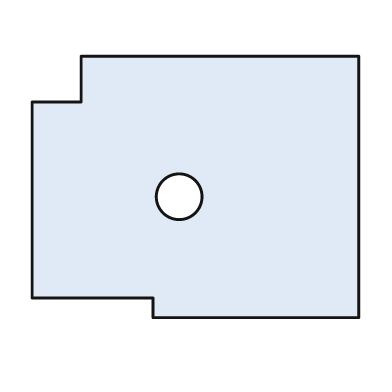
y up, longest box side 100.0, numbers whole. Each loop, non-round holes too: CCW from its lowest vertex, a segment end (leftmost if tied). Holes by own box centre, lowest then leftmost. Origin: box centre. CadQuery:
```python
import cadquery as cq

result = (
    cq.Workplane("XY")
    .moveTo(-13.0, -40.0)
    .lineTo(50.0, -40.0)
    .lineTo(50.0, 40.0)
    .lineTo(-35.0, 40.0)
    .lineTo(-35.0, 26.0)
    .lineTo(-50.0, 26.0)
    .lineTo(-50.0, -34.0)
    .lineTo(-13.0, -34.0)
    .close()
    .moveTo(-5.0, -3.0)
    .circle(7.0)
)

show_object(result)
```